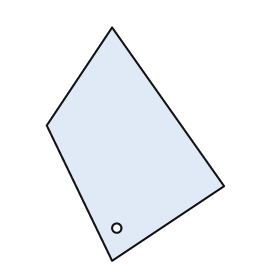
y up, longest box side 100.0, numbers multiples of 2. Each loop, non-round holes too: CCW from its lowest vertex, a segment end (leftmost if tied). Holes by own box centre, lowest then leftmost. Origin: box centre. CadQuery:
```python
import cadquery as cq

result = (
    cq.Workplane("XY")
    .moveTo(-10.0, -50.0)
    .lineTo(38.0, -18.0)
    .lineTo(-10.0, 50.0)
    .lineTo(-38.0, 8.0)
    .close()
    .moveTo(-8.0, -36.0)
    .circle(2.0)
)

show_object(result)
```